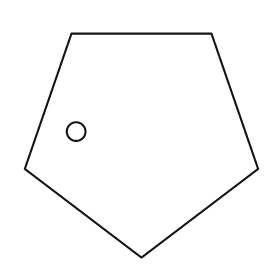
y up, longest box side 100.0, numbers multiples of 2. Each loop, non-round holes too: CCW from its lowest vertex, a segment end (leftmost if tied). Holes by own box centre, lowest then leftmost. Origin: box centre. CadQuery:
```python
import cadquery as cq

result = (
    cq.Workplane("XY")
    .moveTo(0.0, -48.0)
    .lineTo(50.0, -10.0)
    .lineTo(30.0, 48.0)
    .lineTo(-30.0, 48.0)
    .lineTo(-50.0, -10.0)
    .close()
    .moveTo(-28.0, 6.0)
    .circle(4.0)
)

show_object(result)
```